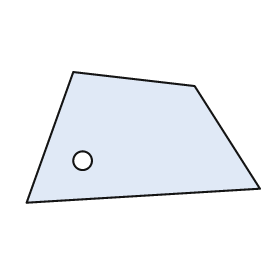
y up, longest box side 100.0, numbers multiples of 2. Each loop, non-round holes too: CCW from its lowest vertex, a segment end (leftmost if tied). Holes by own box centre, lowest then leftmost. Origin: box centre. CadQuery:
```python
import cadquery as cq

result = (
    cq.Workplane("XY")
    .moveTo(-50.0, -28.0)
    .lineTo(50.0, -22.0)
    .lineTo(22.0, 22.0)
    .lineTo(-30.0, 28.0)
    .close()
    .moveTo(-26.0, -10.0)
    .circle(4.0)
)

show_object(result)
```